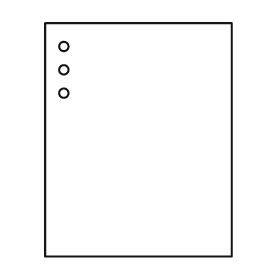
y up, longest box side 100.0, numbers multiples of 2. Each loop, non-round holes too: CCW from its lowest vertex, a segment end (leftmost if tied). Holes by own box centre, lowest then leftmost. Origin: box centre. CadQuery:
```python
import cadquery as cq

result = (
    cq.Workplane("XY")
    .moveTo(-40.0, -50.0)
    .lineTo(40.0, -50.0)
    .lineTo(40.0, 50.0)
    .lineTo(-40.0, 50.0)
    .close()
    .moveTo(-32.0, 20.0)
    .circle(2.0)
    .moveTo(-32.0, 30.0)
    .circle(2.0)
    .moveTo(-32.0, 40.0)
    .circle(2.0)
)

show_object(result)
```